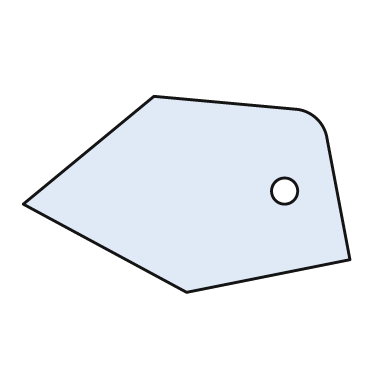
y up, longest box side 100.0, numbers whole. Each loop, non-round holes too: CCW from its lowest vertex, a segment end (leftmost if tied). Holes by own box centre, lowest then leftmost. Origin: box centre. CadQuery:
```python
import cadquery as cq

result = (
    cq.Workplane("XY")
    .moveTo(0.0, -30.0)
    .lineTo(50.0, -20.0)
    .lineTo(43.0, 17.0)
    .threePointArc((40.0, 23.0), (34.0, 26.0))
    .lineTo(-10.0, 30.0)
    .lineTo(-50.0, -3.0)
    .close()
    .moveTo(30.0, 1.0)
    .circle(4.0)
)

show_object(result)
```